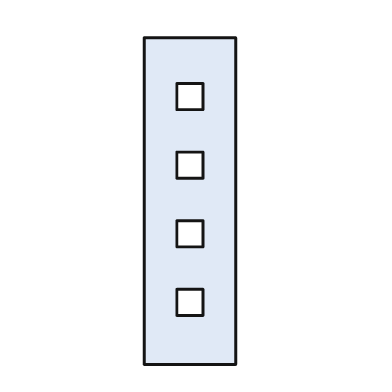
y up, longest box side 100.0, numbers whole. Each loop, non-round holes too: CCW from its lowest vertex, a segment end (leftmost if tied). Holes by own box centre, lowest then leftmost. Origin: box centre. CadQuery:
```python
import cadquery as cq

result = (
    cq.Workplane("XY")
    .moveTo(-14.0, -50.0)
    .lineTo(14.0, -50.0)
    .lineTo(14.0, 50.0)
    .lineTo(-14.0, 50.0)
    .close()
    .moveTo(-4.0, -35.0)
    .lineTo(4.0, -35.0)
    .lineTo(4.0, -27.0)
    .lineTo(-4.0, -27.0)
    .close()
    .moveTo(-4.0, -14.0)
    .lineTo(4.0, -14.0)
    .lineTo(4.0, -6.0)
    .lineTo(-4.0, -6.0)
    .close()
    .moveTo(-4.0, 7.0)
    .lineTo(4.0, 7.0)
    .lineTo(4.0, 15.0)
    .lineTo(-4.0, 15.0)
    .close()
    .moveTo(-4.0, 28.0)
    .lineTo(4.0, 28.0)
    .lineTo(4.0, 36.0)
    .lineTo(-4.0, 36.0)
    .close()
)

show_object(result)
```